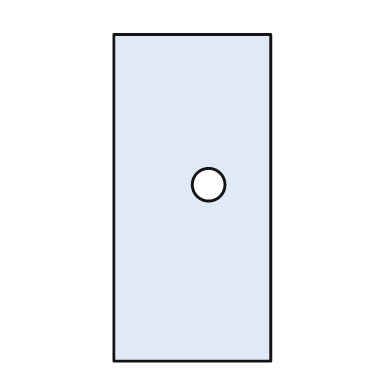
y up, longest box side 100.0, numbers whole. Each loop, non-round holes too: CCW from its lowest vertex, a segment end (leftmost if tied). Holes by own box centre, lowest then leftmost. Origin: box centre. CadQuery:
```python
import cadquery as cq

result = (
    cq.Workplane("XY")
    .moveTo(-24.0, -50.0)
    .lineTo(24.0, -50.0)
    .lineTo(24.0, 50.0)
    .lineTo(-24.0, 50.0)
    .close()
    .moveTo(5.0, 4.0)
    .circle(5.0)
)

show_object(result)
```